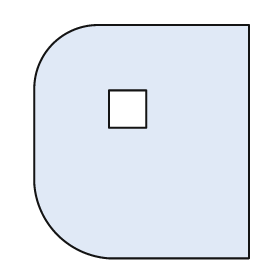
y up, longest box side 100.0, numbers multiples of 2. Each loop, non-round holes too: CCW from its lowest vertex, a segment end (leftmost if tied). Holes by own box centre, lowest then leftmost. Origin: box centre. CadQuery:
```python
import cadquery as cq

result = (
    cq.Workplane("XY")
    .moveTo(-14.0, -50.0)
    .lineTo(46.0, -50.0)
    .lineTo(46.0, 50.0)
    .lineTo(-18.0, 50.0)
    .threePointArc((-38.0, 42.0), (-46.0, 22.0))
    .lineTo(-46.0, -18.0)
    .threePointArc((-36.0, -40.0), (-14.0, -50.0))
    .close()
    .moveTo(-14.0, 6.0)
    .lineTo(2.0, 6.0)
    .lineTo(2.0, 22.0)
    .lineTo(-14.0, 22.0)
    .close()
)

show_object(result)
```